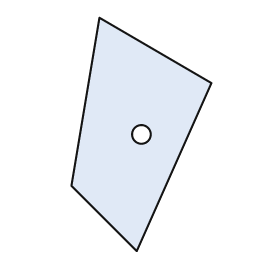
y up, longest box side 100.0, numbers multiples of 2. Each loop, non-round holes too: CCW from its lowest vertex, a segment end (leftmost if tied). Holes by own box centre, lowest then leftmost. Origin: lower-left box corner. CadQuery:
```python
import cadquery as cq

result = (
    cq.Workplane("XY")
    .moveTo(28.0, 0.0)
    .lineTo(60.0, 72.0)
    .lineTo(12.0, 100.0)
    .lineTo(0.0, 28.0)
    .close()
    .moveTo(30.0, 50.0)
    .circle(4.0)
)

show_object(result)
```